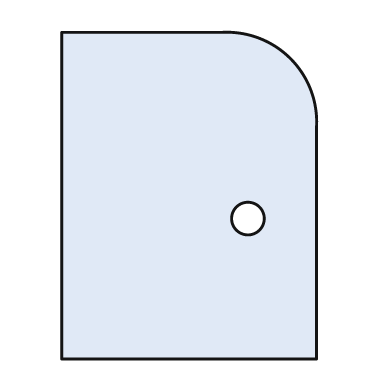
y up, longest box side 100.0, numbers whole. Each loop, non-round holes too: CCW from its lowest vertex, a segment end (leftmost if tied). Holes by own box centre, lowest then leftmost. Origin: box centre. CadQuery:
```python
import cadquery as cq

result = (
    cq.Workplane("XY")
    .moveTo(-39.0, -50.0)
    .lineTo(39.0, -50.0)
    .lineTo(39.0, 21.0)
    .threePointArc((31.0, 42.0), (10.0, 50.0))
    .lineTo(-39.0, 50.0)
    .close()
    .moveTo(18.0, -7.0)
    .circle(5.0)
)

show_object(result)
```